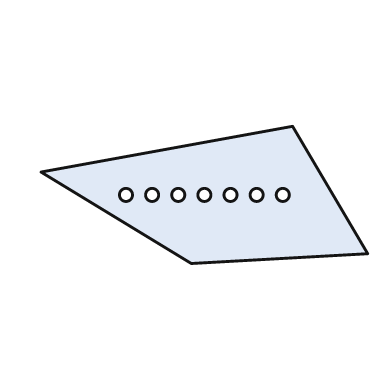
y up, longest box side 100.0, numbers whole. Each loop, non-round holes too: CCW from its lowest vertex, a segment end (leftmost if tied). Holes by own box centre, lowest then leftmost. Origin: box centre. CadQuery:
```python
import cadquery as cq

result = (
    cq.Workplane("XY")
    .moveTo(-4.0, -21.0)
    .lineTo(50.0, -18.0)
    .lineTo(27.0, 21.0)
    .lineTo(-50.0, 7.0)
    .close()
    .moveTo(-24.0, 0.0)
    .circle(2.0)
    .moveTo(-16.0, 0.0)
    .circle(2.0)
    .moveTo(-8.0, 0.0)
    .circle(2.0)
    .moveTo(0.0, 0.0)
    .circle(2.0)
    .moveTo(8.0, 0.0)
    .circle(2.0)
    .moveTo(16.0, 0.0)
    .circle(2.0)
    .moveTo(24.0, 0.0)
    .circle(2.0)
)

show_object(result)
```